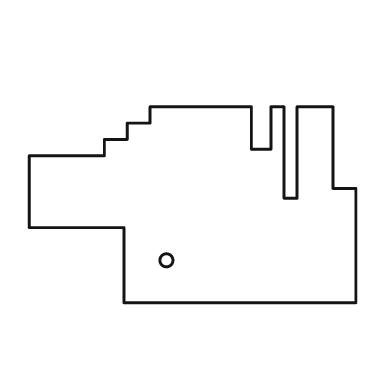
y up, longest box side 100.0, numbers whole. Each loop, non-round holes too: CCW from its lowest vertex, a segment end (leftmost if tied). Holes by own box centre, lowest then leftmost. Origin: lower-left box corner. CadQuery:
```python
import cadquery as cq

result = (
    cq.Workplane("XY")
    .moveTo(29.0, 0.0)
    .lineTo(100.0, 0.0)
    .lineTo(100.0, 35.0)
    .lineTo(93.0, 35.0)
    .lineTo(93.0, 60.0)
    .lineTo(82.0, 60.0)
    .lineTo(82.0, 32.0)
    .lineTo(78.0, 32.0)
    .lineTo(78.0, 60.0)
    .lineTo(74.0, 60.0)
    .lineTo(74.0, 47.0)
    .lineTo(68.0, 47.0)
    .lineTo(68.0, 60.0)
    .lineTo(37.0, 60.0)
    .lineTo(37.0, 55.0)
    .lineTo(30.0, 55.0)
    .lineTo(30.0, 50.0)
    .lineTo(23.0, 50.0)
    .lineTo(23.0, 45.0)
    .lineTo(0.0, 45.0)
    .lineTo(0.0, 23.0)
    .lineTo(29.0, 23.0)
    .close()
    .moveTo(42.0, 13.0)
    .circle(2.0)
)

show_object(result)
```